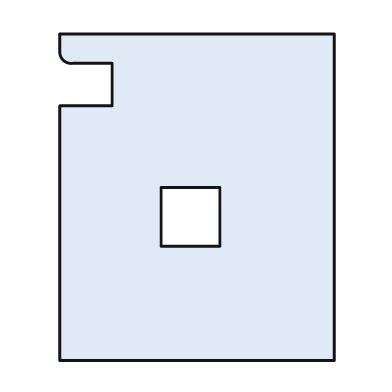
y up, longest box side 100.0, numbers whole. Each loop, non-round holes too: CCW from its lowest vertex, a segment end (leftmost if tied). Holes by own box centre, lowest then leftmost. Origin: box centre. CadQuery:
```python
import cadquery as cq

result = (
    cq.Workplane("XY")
    .moveTo(-42.0, -50.0)
    .lineTo(42.0, -50.0)
    .lineTo(42.0, 50.0)
    .lineTo(-42.0, 50.0)
    .lineTo(-42.0, 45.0)
    .threePointArc((-41.0, 42.0), (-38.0, 41.0))
    .lineTo(-26.0, 41.0)
    .lineTo(-26.0, 28.0)
    .lineTo(-42.0, 28.0)
    .close()
    .moveTo(-11.0, -15.0)
    .lineTo(7.0, -15.0)
    .lineTo(7.0, 3.0)
    .lineTo(-11.0, 3.0)
    .close()
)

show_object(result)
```